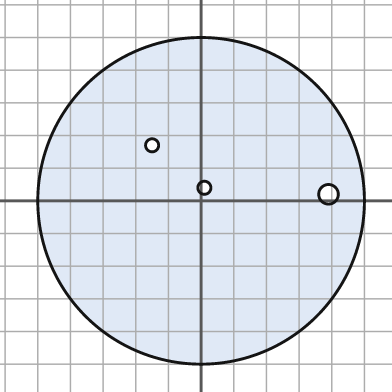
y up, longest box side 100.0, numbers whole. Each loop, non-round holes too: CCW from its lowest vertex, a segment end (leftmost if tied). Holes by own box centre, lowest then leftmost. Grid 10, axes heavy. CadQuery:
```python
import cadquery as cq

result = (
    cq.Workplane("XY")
    .moveTo(0.0, 0.0)
    .circle(50.0)
    .moveTo(39.0, 2.0)
    .circle(3.0)
    .moveTo(1.0, 4.0)
    .circle(2.0)
    .moveTo(-15.0, 17.0)
    .circle(2.0)
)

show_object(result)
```